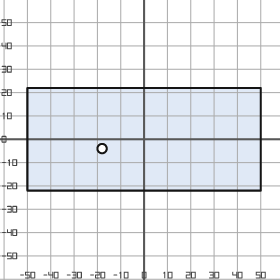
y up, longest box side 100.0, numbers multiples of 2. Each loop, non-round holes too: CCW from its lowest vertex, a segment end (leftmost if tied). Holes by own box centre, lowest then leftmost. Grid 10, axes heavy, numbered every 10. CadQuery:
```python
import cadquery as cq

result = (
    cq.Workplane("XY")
    .moveTo(-50.0, -22.0)
    .lineTo(50.0, -22.0)
    .lineTo(50.0, 22.0)
    .lineTo(-50.0, 22.0)
    .close()
    .moveTo(-18.0, -4.0)
    .circle(2.0)
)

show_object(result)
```